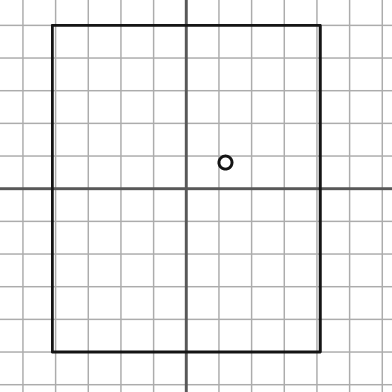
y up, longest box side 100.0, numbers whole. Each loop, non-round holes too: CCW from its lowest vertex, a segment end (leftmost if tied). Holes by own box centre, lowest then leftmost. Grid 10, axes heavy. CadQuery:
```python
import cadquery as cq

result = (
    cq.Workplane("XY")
    .moveTo(-41.0, -50.0)
    .lineTo(41.0, -50.0)
    .lineTo(41.0, 50.0)
    .lineTo(-41.0, 50.0)
    .close()
    .moveTo(12.0, 8.0)
    .circle(2.0)
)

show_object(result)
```